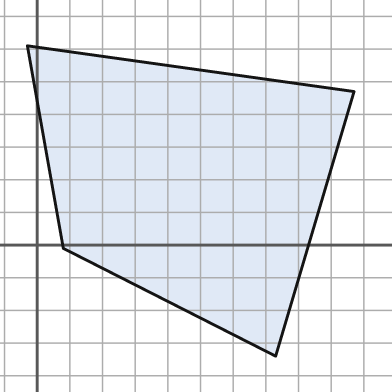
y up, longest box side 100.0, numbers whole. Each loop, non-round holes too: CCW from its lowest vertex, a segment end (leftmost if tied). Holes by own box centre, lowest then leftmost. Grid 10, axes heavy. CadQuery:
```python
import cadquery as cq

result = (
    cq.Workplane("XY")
    .moveTo(73.0, -34.0)
    .lineTo(97.0, 47.0)
    .lineTo(-3.0, 61.0)
    .lineTo(8.0, -1.0)
    .close()
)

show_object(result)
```